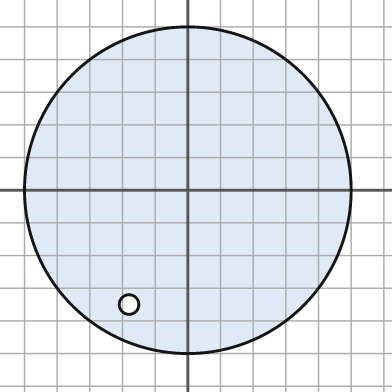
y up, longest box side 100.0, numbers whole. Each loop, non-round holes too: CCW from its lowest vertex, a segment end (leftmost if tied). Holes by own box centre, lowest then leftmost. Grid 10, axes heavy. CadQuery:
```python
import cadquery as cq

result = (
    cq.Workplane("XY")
    .moveTo(0.0, 0.0)
    .circle(50.0)
    .moveTo(-18.0, -35.0)
    .circle(3.0)
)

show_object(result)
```